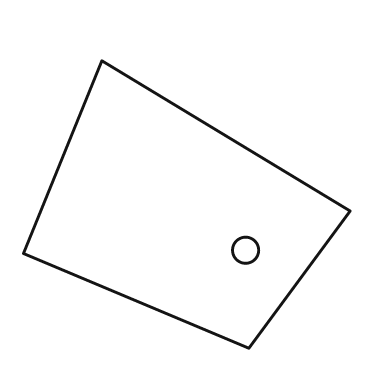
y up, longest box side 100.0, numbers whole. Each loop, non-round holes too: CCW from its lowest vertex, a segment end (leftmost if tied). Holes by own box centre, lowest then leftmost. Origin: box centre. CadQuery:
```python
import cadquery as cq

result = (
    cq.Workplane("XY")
    .moveTo(19.0, -44.0)
    .lineTo(50.0, -2.0)
    .lineTo(-26.0, 44.0)
    .lineTo(-50.0, -15.0)
    .close()
    .moveTo(18.0, -14.0)
    .circle(4.0)
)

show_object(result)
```